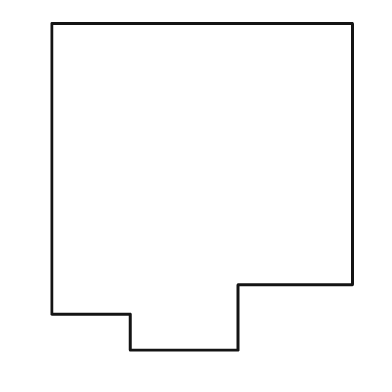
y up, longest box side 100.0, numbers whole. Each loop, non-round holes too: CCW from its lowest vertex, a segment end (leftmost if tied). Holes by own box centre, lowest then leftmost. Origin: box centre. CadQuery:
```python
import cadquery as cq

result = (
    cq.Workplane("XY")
    .moveTo(-22.0, -50.0)
    .lineTo(11.0, -50.0)
    .lineTo(11.0, -30.0)
    .lineTo(46.0, -30.0)
    .lineTo(46.0, 50.0)
    .lineTo(-46.0, 50.0)
    .lineTo(-46.0, -39.0)
    .lineTo(-22.0, -39.0)
    .close()
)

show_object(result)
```